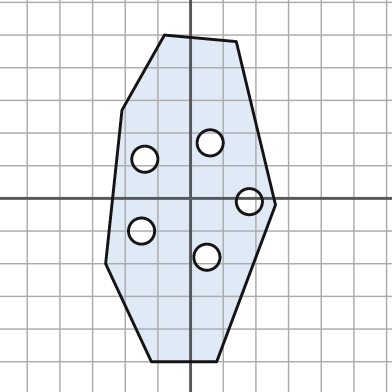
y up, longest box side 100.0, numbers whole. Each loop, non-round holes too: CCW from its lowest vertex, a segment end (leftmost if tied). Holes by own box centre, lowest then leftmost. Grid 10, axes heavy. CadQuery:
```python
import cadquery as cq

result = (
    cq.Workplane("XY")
    .moveTo(-12.0, -50.0)
    .lineTo(8.0, -50.0)
    .lineTo(26.0, -2.0)
    .lineTo(14.0, 48.0)
    .lineTo(-8.0, 50.0)
    .lineTo(-21.0, 27.0)
    .lineTo(-26.0, -20.0)
    .close()
    .moveTo(5.0, -18.0)
    .circle(4.0)
    .moveTo(-15.0, -10.0)
    .circle(4.0)
    .moveTo(18.0, -1.0)
    .circle(4.0)
    .moveTo(-14.0, 12.0)
    .circle(4.0)
    .moveTo(6.0, 17.0)
    .circle(4.0)
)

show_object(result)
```